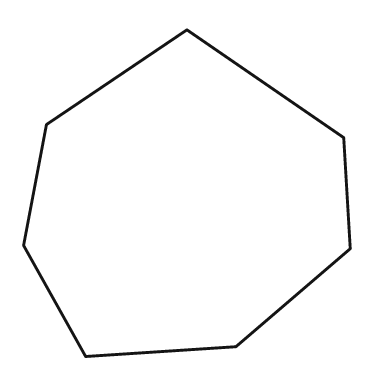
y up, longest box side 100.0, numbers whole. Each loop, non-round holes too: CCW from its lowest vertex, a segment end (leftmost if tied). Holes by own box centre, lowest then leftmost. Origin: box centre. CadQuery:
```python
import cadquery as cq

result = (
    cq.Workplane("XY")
    .moveTo(-31.0, -50.0)
    .lineTo(15.0, -47.0)
    .lineTo(50.0, -17.0)
    .lineTo(48.0, 17.0)
    .lineTo(0.0, 50.0)
    .lineTo(-43.0, 21.0)
    .lineTo(-50.0, -16.0)
    .close()
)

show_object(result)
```